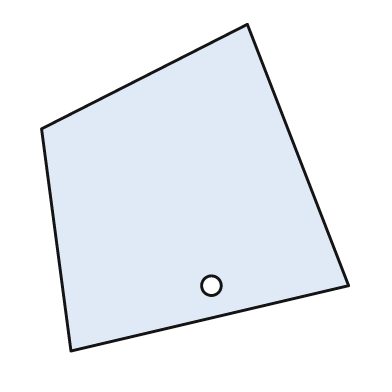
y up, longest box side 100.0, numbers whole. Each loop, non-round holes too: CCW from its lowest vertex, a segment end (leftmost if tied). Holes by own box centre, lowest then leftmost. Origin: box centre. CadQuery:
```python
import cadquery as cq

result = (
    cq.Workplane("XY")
    .moveTo(-38.0, -50.0)
    .lineTo(47.0, -30.0)
    .lineTo(16.0, 50.0)
    .lineTo(-47.0, 18.0)
    .close()
    .moveTo(5.0, -30.0)
    .circle(3.0)
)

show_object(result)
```